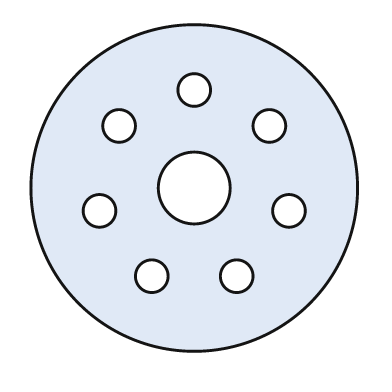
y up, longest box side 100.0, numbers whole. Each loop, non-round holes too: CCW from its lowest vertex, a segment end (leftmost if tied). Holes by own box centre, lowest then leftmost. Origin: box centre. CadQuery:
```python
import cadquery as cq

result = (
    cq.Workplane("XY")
    .moveTo(0.0, 0.0)
    .circle(50.0)
    .moveTo(-13.0, -27.0)
    .circle(5.0)
    .moveTo(13.0, -27.0)
    .circle(5.0)
    .moveTo(-29.0, -7.0)
    .circle(5.0)
    .moveTo(29.0, -7.0)
    .circle(5.0)
    .moveTo(0.0, 0.0)
    .circle(11.0)
    .moveTo(-23.0, 19.0)
    .circle(5.0)
    .moveTo(23.0, 19.0)
    .circle(5.0)
    .moveTo(0.0, 30.0)
    .circle(5.0)
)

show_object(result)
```